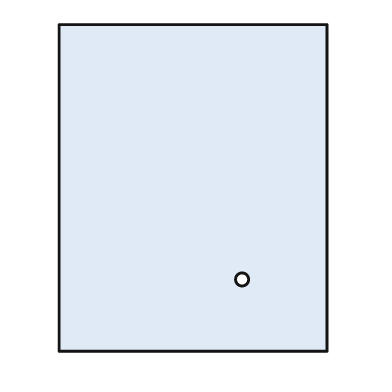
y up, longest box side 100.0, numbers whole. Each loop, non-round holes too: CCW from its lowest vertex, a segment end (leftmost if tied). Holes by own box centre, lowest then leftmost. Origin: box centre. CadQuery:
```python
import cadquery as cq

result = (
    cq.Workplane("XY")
    .moveTo(-41.0, -50.0)
    .lineTo(41.0, -50.0)
    .lineTo(41.0, 50.0)
    .lineTo(-41.0, 50.0)
    .close()
    .moveTo(15.0, -28.0)
    .circle(2.0)
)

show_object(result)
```